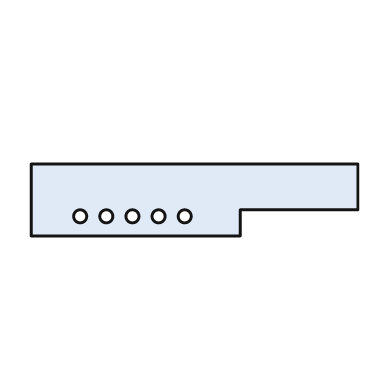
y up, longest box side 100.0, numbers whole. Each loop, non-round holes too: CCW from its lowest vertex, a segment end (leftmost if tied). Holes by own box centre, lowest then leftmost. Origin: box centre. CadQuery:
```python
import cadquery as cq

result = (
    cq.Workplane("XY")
    .moveTo(-50.0, -11.0)
    .lineTo(14.0, -11.0)
    .lineTo(14.0, -3.0)
    .lineTo(50.0, -3.0)
    .lineTo(50.0, 11.0)
    .lineTo(-50.0, 11.0)
    .close()
    .moveTo(-35.0, -5.0)
    .circle(2.0)
    .moveTo(-27.0, -5.0)
    .circle(2.0)
    .moveTo(-19.0, -5.0)
    .circle(2.0)
    .moveTo(-11.0, -5.0)
    .circle(2.0)
    .moveTo(-3.0, -5.0)
    .circle(2.0)
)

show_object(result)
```